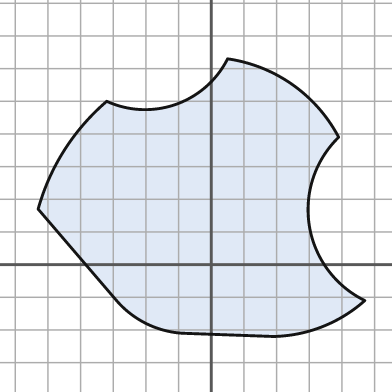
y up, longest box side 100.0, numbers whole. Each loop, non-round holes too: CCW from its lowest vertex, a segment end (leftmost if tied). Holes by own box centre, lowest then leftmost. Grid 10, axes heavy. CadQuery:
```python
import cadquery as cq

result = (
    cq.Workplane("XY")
    .moveTo(19.0, -22.0)
    .threePointArc((34.0, -19.0), (47.0, -11.0))
    .threePointArc((30.0, 12.0), (39.0, 39.0))
    .threePointArc((25.0, 55.0), (5.0, 63.0))
    .threePointArc((-11.0, 49.0), (-32.0, 50.0))
    .threePointArc((-45.0, 35.0), (-53.0, 17.0))
    .lineTo(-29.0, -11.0)
    .threePointArc((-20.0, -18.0), (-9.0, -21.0))
    .close()
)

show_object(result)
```